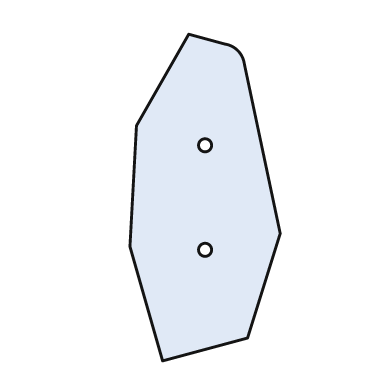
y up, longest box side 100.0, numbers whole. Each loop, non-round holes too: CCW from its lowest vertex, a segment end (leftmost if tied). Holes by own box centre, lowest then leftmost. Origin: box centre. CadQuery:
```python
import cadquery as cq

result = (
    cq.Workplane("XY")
    .moveTo(-13.0, -50.0)
    .lineTo(13.0, -43.0)
    .lineTo(23.0, -11.0)
    .lineTo(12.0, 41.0)
    .threePointArc((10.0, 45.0), (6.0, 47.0))
    .lineTo(-5.0, 50.0)
    .lineTo(-21.0, 22.0)
    .lineTo(-23.0, -15.0)
    .close()
    .moveTo(0.0, -16.0)
    .circle(2.0)
    .moveTo(0.0, 16.0)
    .circle(2.0)
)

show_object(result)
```